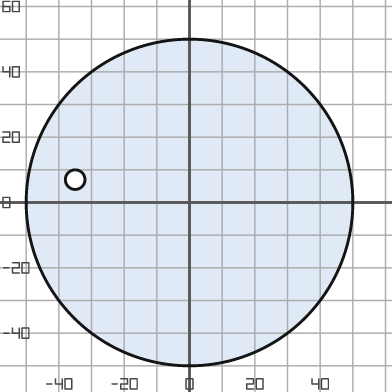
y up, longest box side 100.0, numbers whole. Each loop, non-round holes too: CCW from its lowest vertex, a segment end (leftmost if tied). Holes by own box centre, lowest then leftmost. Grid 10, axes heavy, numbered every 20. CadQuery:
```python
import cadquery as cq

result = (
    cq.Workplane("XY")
    .moveTo(0.0, 0.0)
    .circle(50.0)
    .moveTo(-35.0, 7.0)
    .circle(3.0)
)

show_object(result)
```